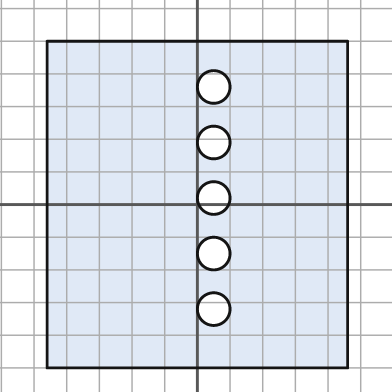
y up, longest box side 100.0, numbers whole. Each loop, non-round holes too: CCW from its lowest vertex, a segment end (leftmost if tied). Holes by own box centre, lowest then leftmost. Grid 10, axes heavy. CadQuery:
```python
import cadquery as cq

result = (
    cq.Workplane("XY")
    .moveTo(-46.0, -50.0)
    .lineTo(46.0, -50.0)
    .lineTo(46.0, 50.0)
    .lineTo(-46.0, 50.0)
    .close()
    .moveTo(5.0, -32.0)
    .circle(5.0)
    .moveTo(5.0, -15.0)
    .circle(5.0)
    .moveTo(5.0, 2.0)
    .circle(5.0)
    .moveTo(5.0, 19.0)
    .circle(5.0)
    .moveTo(5.0, 36.0)
    .circle(5.0)
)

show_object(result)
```